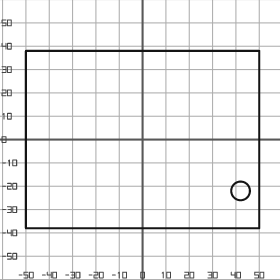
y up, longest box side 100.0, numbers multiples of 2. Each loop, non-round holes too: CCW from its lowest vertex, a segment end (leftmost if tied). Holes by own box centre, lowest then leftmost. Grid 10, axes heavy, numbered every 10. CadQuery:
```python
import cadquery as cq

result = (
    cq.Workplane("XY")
    .moveTo(-50.0, -38.0)
    .lineTo(50.0, -38.0)
    .lineTo(50.0, 38.0)
    .lineTo(-50.0, 38.0)
    .close()
    .moveTo(42.0, -22.0)
    .circle(4.0)
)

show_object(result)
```